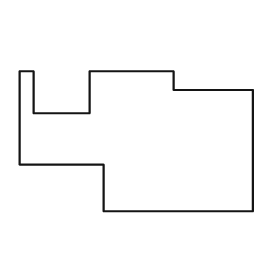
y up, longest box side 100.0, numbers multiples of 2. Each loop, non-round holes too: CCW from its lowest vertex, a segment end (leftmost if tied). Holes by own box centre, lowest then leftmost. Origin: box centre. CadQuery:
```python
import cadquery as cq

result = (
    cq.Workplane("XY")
    .moveTo(-14.0, -30.0)
    .lineTo(50.0, -30.0)
    .lineTo(50.0, 22.0)
    .lineTo(16.0, 22.0)
    .lineTo(16.0, 30.0)
    .lineTo(-20.0, 30.0)
    .lineTo(-20.0, 12.0)
    .lineTo(-44.0, 12.0)
    .lineTo(-44.0, 30.0)
    .lineTo(-50.0, 30.0)
    .lineTo(-50.0, -10.0)
    .lineTo(-14.0, -10.0)
    .close()
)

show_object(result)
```